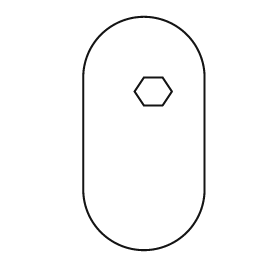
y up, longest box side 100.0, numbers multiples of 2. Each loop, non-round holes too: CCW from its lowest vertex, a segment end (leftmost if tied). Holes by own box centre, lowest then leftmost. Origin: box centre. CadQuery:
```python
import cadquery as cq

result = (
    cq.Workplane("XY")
    .moveTo(-26.0, -24.0)
    .threePointArc((0.0, -50.0), (26.0, -24.0))
    .lineTo(26.0, 24.0)
    .threePointArc((0.0, 50.0), (-26.0, 24.0))
    .close()
    .moveTo(0.0, 12.0)
    .lineTo(8.0, 12.0)
    .lineTo(12.0, 18.0)
    .lineTo(8.0, 24.0)
    .lineTo(0.0, 24.0)
    .lineTo(-4.0, 18.0)
    .close()
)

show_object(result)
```